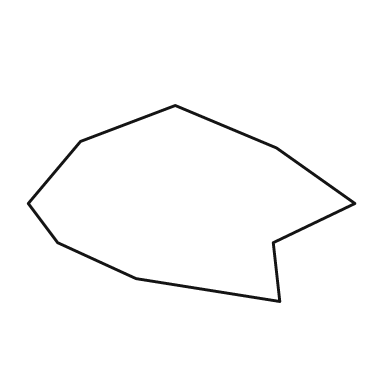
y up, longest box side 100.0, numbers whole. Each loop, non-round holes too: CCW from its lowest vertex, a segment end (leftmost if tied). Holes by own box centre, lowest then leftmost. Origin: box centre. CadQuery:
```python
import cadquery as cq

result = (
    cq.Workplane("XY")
    .moveTo(27.0, -30.0)
    .lineTo(25.0, -12.0)
    .lineTo(50.0, 0.0)
    .lineTo(26.0, 17.0)
    .lineTo(-5.0, 30.0)
    .lineTo(-34.0, 19.0)
    .lineTo(-50.0, 0.0)
    .lineTo(-41.0, -12.0)
    .lineTo(-17.0, -23.0)
    .close()
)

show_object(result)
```